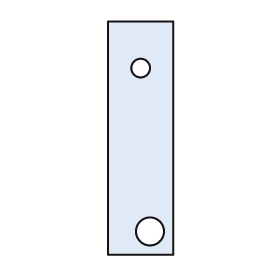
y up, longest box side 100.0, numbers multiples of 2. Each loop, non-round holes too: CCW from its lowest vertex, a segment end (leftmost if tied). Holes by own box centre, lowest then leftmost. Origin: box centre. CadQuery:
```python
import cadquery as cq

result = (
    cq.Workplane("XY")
    .moveTo(-14.0, -50.0)
    .lineTo(14.0, -50.0)
    .lineTo(14.0, 50.0)
    .lineTo(-14.0, 50.0)
    .close()
    .moveTo(4.0, -40.0)
    .circle(6.0)
    .moveTo(0.0, 30.0)
    .circle(4.0)
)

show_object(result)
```